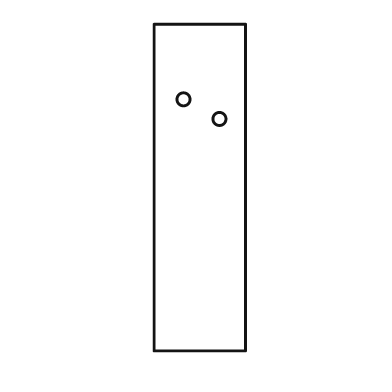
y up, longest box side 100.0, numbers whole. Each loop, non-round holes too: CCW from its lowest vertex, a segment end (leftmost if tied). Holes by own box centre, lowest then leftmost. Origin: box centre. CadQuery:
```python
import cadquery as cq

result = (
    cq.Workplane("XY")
    .moveTo(-14.0, -50.0)
    .lineTo(14.0, -50.0)
    .lineTo(14.0, 50.0)
    .lineTo(-14.0, 50.0)
    .close()
    .moveTo(6.0, 21.0)
    .circle(2.0)
    .moveTo(-5.0, 27.0)
    .circle(2.0)
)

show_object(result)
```